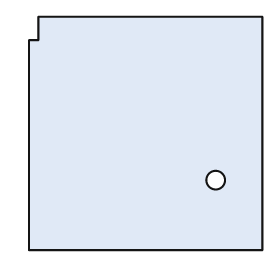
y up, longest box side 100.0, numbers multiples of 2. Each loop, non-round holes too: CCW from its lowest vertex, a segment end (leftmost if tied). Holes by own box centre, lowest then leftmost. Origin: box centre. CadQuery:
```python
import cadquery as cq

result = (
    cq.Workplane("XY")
    .moveTo(-50.0, -50.0)
    .lineTo(50.0, -50.0)
    .lineTo(50.0, 50.0)
    .lineTo(-46.0, 50.0)
    .lineTo(-46.0, 40.0)
    .lineTo(-50.0, 40.0)
    .close()
    .moveTo(30.0, -20.0)
    .circle(4.0)
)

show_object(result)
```